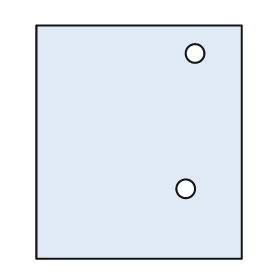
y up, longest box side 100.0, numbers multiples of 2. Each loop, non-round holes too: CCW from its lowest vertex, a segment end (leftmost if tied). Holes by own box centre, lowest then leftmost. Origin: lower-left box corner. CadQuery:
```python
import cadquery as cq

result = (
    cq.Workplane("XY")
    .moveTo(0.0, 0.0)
    .lineTo(88.0, 0.0)
    .lineTo(88.0, 100.0)
    .lineTo(0.0, 100.0)
    .close()
    .moveTo(64.0, 30.0)
    .circle(4.0)
    .moveTo(68.0, 88.0)
    .circle(4.0)
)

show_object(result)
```